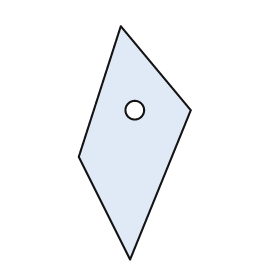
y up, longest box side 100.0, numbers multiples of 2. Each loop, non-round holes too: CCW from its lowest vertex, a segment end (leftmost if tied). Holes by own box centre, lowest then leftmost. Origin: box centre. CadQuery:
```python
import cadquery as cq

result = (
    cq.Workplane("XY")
    .moveTo(-2.0, -50.0)
    .lineTo(24.0, 14.0)
    .lineTo(-6.0, 50.0)
    .lineTo(-24.0, -6.0)
    .close()
    .moveTo(0.0, 14.0)
    .circle(4.0)
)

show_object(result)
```